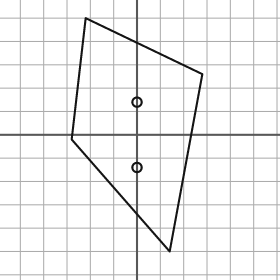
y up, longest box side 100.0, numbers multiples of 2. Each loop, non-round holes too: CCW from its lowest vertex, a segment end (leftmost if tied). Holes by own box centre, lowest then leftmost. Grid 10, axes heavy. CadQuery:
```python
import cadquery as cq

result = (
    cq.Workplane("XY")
    .moveTo(14.0, -50.0)
    .lineTo(28.0, 26.0)
    .lineTo(-22.0, 50.0)
    .lineTo(-28.0, -2.0)
    .close()
    .moveTo(0.0, -14.0)
    .circle(2.0)
    .moveTo(0.0, 14.0)
    .circle(2.0)
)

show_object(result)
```